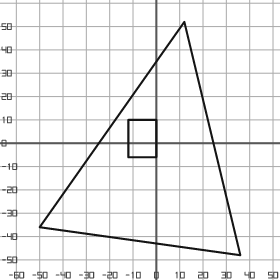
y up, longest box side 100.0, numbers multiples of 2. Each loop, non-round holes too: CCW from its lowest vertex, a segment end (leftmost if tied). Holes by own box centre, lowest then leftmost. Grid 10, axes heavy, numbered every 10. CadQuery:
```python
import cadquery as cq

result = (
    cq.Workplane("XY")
    .moveTo(36.0, -48.0)
    .lineTo(12.0, 52.0)
    .lineTo(-50.0, -36.0)
    .close()
    .moveTo(-12.0, -6.0)
    .lineTo(0.0, -6.0)
    .lineTo(0.0, 10.0)
    .lineTo(-12.0, 10.0)
    .close()
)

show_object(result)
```